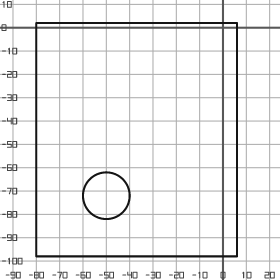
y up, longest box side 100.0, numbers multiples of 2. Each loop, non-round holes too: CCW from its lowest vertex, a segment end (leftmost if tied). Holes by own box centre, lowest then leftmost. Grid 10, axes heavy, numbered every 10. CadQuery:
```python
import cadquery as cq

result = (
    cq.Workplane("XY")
    .moveTo(-80.0, -98.0)
    .lineTo(6.0, -98.0)
    .lineTo(6.0, 2.0)
    .lineTo(-80.0, 2.0)
    .close()
    .moveTo(-50.0, -72.0)
    .circle(10.0)
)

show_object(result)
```